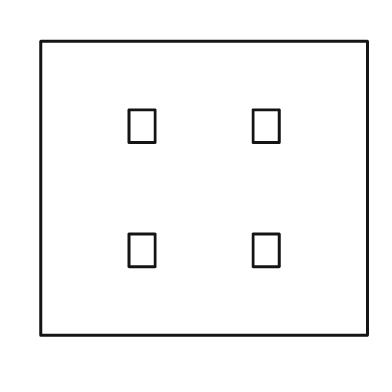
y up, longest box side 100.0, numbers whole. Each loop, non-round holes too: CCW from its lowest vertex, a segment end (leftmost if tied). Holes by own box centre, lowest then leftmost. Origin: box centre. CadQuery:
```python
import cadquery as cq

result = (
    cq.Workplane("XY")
    .moveTo(-50.0, -45.0)
    .lineTo(50.0, -45.0)
    .lineTo(50.0, 45.0)
    .lineTo(-50.0, 45.0)
    .close()
    .moveTo(-23.0, -24.0)
    .lineTo(-15.0, -24.0)
    .lineTo(-15.0, -14.0)
    .lineTo(-23.0, -14.0)
    .close()
    .moveTo(15.0, -24.0)
    .lineTo(23.0, -24.0)
    .lineTo(23.0, -14.0)
    .lineTo(15.0, -14.0)
    .close()
    .moveTo(-23.0, 14.0)
    .lineTo(-15.0, 14.0)
    .lineTo(-15.0, 24.0)
    .lineTo(-23.0, 24.0)
    .close()
    .moveTo(15.0, 14.0)
    .lineTo(23.0, 14.0)
    .lineTo(23.0, 24.0)
    .lineTo(15.0, 24.0)
    .close()
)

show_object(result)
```